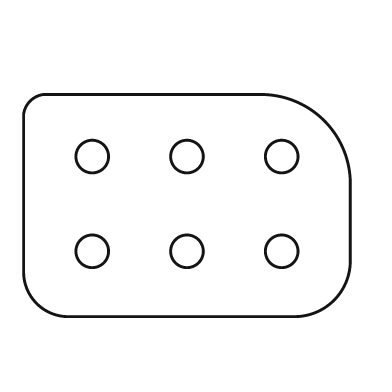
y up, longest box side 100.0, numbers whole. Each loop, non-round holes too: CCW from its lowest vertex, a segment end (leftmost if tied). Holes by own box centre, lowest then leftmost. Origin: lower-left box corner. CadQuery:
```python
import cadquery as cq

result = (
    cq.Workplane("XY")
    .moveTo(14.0, 0.0)
    .lineTo(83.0, 0.0)
    .threePointArc((95.0, 5.0), (100.0, 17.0))
    .lineTo(100.0, 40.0)
    .threePointArc((92.0, 60.0), (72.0, 68.0))
    .lineTo(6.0, 68.0)
    .threePointArc((2.0, 66.0), (0.0, 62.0))
    .lineTo(0.0, 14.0)
    .threePointArc((4.0, 4.0), (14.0, 0.0))
    .close()
    .moveTo(21.0, 20.0)
    .circle(5.0)
    .moveTo(50.0, 20.0)
    .circle(5.0)
    .moveTo(79.0, 20.0)
    .circle(5.0)
    .moveTo(21.0, 49.0)
    .circle(5.0)
    .moveTo(50.0, 49.0)
    .circle(5.0)
    .moveTo(79.0, 49.0)
    .circle(5.0)
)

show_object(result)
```